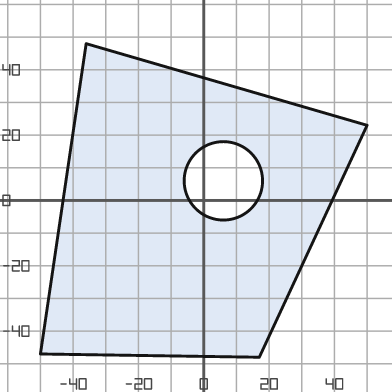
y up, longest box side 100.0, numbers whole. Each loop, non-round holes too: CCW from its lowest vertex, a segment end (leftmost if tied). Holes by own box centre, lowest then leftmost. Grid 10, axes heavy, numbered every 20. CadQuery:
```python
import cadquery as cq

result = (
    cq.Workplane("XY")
    .moveTo(17.0, -48.0)
    .lineTo(50.0, 23.0)
    .lineTo(-36.0, 48.0)
    .lineTo(-50.0, -47.0)
    .close()
    .moveTo(6.0, 6.0)
    .circle(12.0)
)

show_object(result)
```